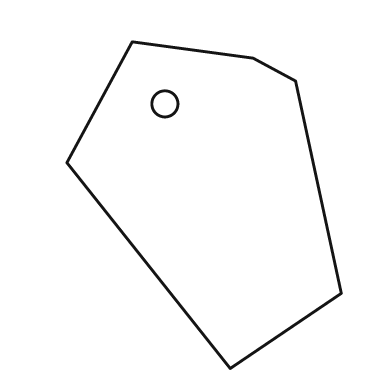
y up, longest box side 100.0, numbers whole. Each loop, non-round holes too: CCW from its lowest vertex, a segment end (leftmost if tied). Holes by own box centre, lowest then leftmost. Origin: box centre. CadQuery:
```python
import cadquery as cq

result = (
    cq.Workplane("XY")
    .moveTo(8.0, -50.0)
    .lineTo(42.0, -27.0)
    .lineTo(28.0, 38.0)
    .lineTo(15.0, 45.0)
    .lineTo(-22.0, 50.0)
    .lineTo(-42.0, 13.0)
    .close()
    .moveTo(-12.0, 31.0)
    .circle(4.0)
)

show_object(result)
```